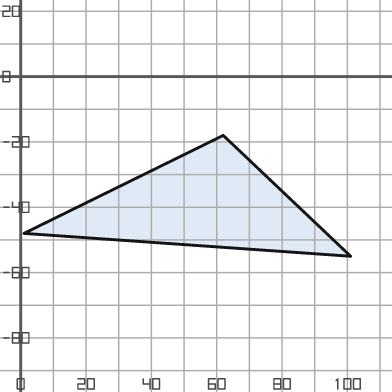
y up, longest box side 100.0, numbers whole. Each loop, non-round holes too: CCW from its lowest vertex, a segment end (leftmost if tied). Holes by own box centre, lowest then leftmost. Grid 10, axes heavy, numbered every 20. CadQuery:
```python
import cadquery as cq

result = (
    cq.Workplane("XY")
    .moveTo(101.0, -55.0)
    .lineTo(62.0, -18.0)
    .lineTo(1.0, -48.0)
    .close()
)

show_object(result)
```